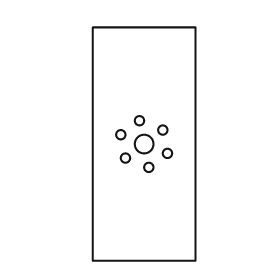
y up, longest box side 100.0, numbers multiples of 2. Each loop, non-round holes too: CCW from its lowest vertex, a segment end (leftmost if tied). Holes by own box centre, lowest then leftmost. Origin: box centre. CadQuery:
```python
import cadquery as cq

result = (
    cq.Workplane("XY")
    .moveTo(-22.0, -50.0)
    .lineTo(22.0, -50.0)
    .lineTo(22.0, 50.0)
    .lineTo(-22.0, 50.0)
    .close()
    .moveTo(2.0, -10.0)
    .circle(2.0)
    .moveTo(-8.0, -6.0)
    .circle(2.0)
    .moveTo(10.0, -4.0)
    .circle(2.0)
    .moveTo(0.0, 0.0)
    .circle(4.0)
    .moveTo(-10.0, 4.0)
    .circle(2.0)
    .moveTo(8.0, 6.0)
    .circle(2.0)
    .moveTo(-2.0, 10.0)
    .circle(2.0)
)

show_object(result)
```